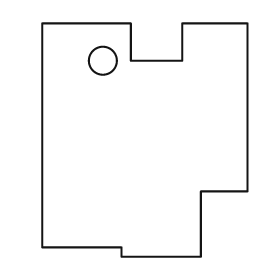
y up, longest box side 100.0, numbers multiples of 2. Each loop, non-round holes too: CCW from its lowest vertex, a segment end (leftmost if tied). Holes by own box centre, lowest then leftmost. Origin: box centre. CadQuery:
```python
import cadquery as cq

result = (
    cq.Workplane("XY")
    .moveTo(-10.0, -50.0)
    .lineTo(24.0, -50.0)
    .lineTo(24.0, -22.0)
    .lineTo(44.0, -22.0)
    .lineTo(44.0, 50.0)
    .lineTo(16.0, 50.0)
    .lineTo(16.0, 34.0)
    .lineTo(-6.0, 34.0)
    .lineTo(-6.0, 50.0)
    .lineTo(-44.0, 50.0)
    .lineTo(-44.0, -46.0)
    .lineTo(-10.0, -46.0)
    .close()
    .moveTo(-18.0, 34.0)
    .circle(6.0)
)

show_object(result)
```